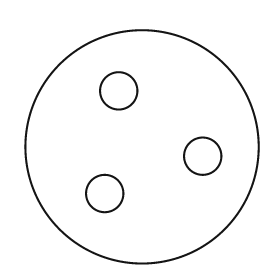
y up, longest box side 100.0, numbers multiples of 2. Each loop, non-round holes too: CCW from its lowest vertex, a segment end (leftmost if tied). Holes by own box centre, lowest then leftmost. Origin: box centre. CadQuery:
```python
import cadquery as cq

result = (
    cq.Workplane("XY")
    .moveTo(0.0, 0.0)
    .circle(50.0)
    .moveTo(-16.0, -20.0)
    .circle(8.0)
    .moveTo(26.0, -4.0)
    .circle(8.0)
    .moveTo(-10.0, 24.0)
    .circle(8.0)
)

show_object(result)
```